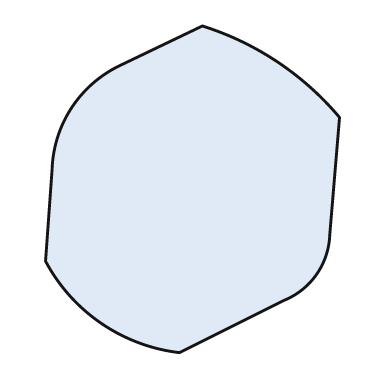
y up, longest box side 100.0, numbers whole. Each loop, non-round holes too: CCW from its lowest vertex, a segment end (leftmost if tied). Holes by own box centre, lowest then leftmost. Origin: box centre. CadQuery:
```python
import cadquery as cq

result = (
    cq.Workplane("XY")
    .moveTo(-4.0, -50.0)
    .lineTo(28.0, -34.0)
    .threePointArc((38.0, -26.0), (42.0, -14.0))
    .lineTo(45.0, 22.0)
    .threePointArc((26.0, 39.0), (3.0, 50.0))
    .lineTo(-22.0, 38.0)
    .threePointArc((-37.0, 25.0), (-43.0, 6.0))
    .lineTo(-45.0, -22.0)
    .threePointArc((-28.0, -41.0), (-4.0, -50.0))
    .close()
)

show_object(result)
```